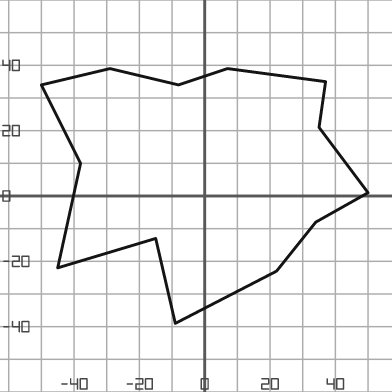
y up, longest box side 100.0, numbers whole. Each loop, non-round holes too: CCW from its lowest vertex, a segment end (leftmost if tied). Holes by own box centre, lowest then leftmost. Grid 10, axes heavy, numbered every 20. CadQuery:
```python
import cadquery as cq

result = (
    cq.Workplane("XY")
    .moveTo(-9.0, -39.0)
    .lineTo(22.0, -23.0)
    .lineTo(34.0, -8.0)
    .lineTo(50.0, 1.0)
    .lineTo(35.0, 21.0)
    .lineTo(37.0, 35.0)
    .lineTo(7.0, 39.0)
    .lineTo(-8.0, 34.0)
    .lineTo(-29.0, 39.0)
    .lineTo(-50.0, 34.0)
    .lineTo(-38.0, 10.0)
    .lineTo(-45.0, -22.0)
    .lineTo(-15.0, -13.0)
    .close()
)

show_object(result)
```